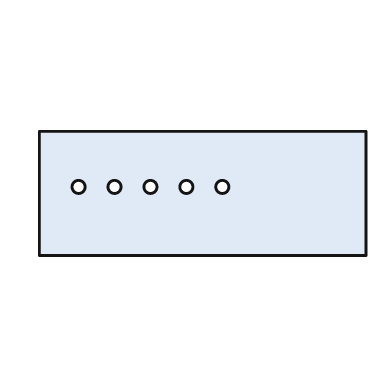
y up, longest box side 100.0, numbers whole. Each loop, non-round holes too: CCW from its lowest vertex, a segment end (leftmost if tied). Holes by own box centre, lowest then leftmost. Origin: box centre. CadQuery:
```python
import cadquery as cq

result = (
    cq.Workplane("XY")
    .moveTo(-50.0, -19.0)
    .lineTo(50.0, -19.0)
    .lineTo(50.0, 19.0)
    .lineTo(-50.0, 19.0)
    .close()
    .moveTo(-38.0, 2.0)
    .circle(2.0)
    .moveTo(-27.0, 2.0)
    .circle(2.0)
    .moveTo(-16.0, 2.0)
    .circle(2.0)
    .moveTo(-5.0, 2.0)
    .circle(2.0)
    .moveTo(6.0, 2.0)
    .circle(2.0)
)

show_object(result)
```